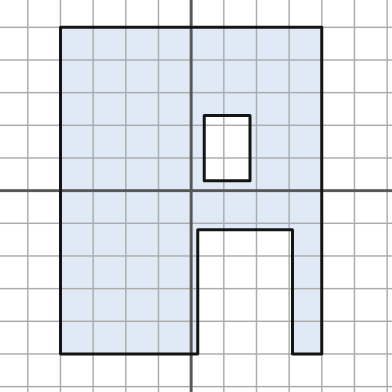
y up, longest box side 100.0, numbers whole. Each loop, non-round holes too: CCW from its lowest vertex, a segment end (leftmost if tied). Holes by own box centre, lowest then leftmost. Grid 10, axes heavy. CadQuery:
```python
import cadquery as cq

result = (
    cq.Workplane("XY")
    .moveTo(-40.0, -50.0)
    .lineTo(2.0, -50.0)
    .lineTo(2.0, -12.0)
    .lineTo(31.0, -12.0)
    .lineTo(31.0, -50.0)
    .lineTo(40.0, -50.0)
    .lineTo(40.0, 50.0)
    .lineTo(-40.0, 50.0)
    .close()
    .moveTo(4.0, 3.0)
    .lineTo(18.0, 3.0)
    .lineTo(18.0, 23.0)
    .lineTo(4.0, 23.0)
    .close()
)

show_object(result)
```